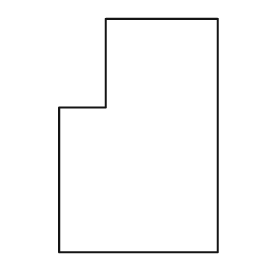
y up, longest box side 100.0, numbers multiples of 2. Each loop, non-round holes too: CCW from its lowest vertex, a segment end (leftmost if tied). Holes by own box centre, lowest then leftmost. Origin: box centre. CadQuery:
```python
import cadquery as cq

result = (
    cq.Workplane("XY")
    .moveTo(-34.0, -50.0)
    .lineTo(34.0, -50.0)
    .lineTo(34.0, 50.0)
    .lineTo(-14.0, 50.0)
    .lineTo(-14.0, 12.0)
    .lineTo(-34.0, 12.0)
    .close()
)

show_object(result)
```